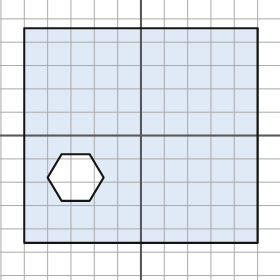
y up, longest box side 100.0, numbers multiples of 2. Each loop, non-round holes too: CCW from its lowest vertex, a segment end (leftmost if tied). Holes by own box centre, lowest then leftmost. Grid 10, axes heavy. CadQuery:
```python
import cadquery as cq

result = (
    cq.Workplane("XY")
    .moveTo(-50.0, -46.0)
    .lineTo(50.0, -46.0)
    .lineTo(50.0, 46.0)
    .lineTo(-50.0, 46.0)
    .close()
    .moveTo(-34.0, -28.0)
    .lineTo(-22.0, -28.0)
    .lineTo(-16.0, -18.0)
    .lineTo(-22.0, -8.0)
    .lineTo(-34.0, -8.0)
    .lineTo(-40.0, -18.0)
    .close()
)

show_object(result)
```